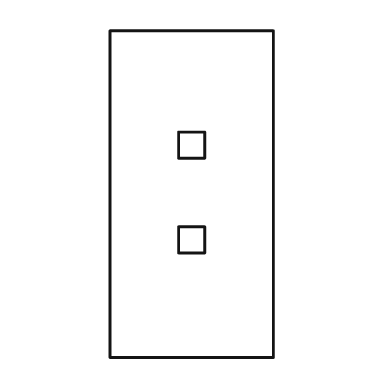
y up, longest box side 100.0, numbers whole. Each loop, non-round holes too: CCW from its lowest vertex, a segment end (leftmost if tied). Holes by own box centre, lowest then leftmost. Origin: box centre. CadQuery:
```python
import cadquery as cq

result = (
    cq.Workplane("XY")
    .moveTo(-25.0, -50.0)
    .lineTo(25.0, -50.0)
    .lineTo(25.0, 50.0)
    .lineTo(-25.0, 50.0)
    .close()
    .moveTo(-4.0, -18.0)
    .lineTo(4.0, -18.0)
    .lineTo(4.0, -10.0)
    .lineTo(-4.0, -10.0)
    .close()
    .moveTo(-4.0, 11.0)
    .lineTo(4.0, 11.0)
    .lineTo(4.0, 19.0)
    .lineTo(-4.0, 19.0)
    .close()
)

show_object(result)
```